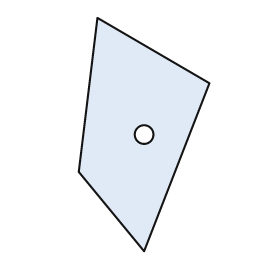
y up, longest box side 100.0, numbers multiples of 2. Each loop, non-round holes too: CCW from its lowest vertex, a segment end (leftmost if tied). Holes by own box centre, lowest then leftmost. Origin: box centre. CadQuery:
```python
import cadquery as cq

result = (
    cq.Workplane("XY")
    .moveTo(0.0, -50.0)
    .lineTo(28.0, 22.0)
    .lineTo(-20.0, 50.0)
    .lineTo(-28.0, -16.0)
    .close()
    .moveTo(0.0, 0.0)
    .circle(4.0)
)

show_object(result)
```